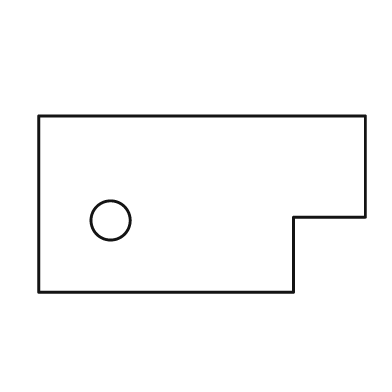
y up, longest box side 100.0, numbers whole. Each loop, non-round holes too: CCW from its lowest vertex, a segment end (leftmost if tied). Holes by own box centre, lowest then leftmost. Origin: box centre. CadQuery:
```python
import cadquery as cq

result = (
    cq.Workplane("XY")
    .moveTo(-50.0, -27.0)
    .lineTo(28.0, -27.0)
    .lineTo(28.0, -4.0)
    .lineTo(50.0, -4.0)
    .lineTo(50.0, 27.0)
    .lineTo(-50.0, 27.0)
    .close()
    .moveTo(-28.0, -5.0)
    .circle(6.0)
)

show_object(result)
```